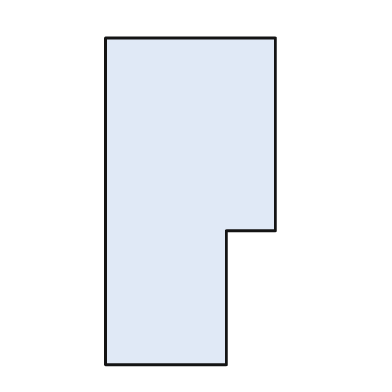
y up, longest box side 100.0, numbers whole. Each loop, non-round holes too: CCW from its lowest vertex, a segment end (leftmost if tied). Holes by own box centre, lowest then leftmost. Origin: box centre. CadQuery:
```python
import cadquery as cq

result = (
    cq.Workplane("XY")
    .moveTo(-26.0, -50.0)
    .lineTo(11.0, -50.0)
    .lineTo(11.0, -9.0)
    .lineTo(26.0, -9.0)
    .lineTo(26.0, 50.0)
    .lineTo(-26.0, 50.0)
    .close()
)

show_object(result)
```